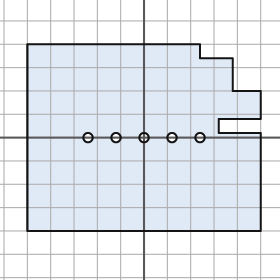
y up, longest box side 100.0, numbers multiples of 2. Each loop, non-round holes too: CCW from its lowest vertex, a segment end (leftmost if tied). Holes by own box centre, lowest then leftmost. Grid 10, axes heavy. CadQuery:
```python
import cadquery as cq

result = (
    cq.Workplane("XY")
    .moveTo(-50.0, -40.0)
    .lineTo(50.0, -40.0)
    .lineTo(50.0, 2.0)
    .lineTo(32.0, 2.0)
    .lineTo(32.0, 8.0)
    .lineTo(50.0, 8.0)
    .lineTo(50.0, 20.0)
    .lineTo(38.0, 20.0)
    .lineTo(38.0, 34.0)
    .lineTo(24.0, 34.0)
    .lineTo(24.0, 40.0)
    .lineTo(-50.0, 40.0)
    .close()
    .moveTo(-24.0, 0.0)
    .circle(2.0)
    .moveTo(-12.0, 0.0)
    .circle(2.0)
    .moveTo(0.0, 0.0)
    .circle(2.0)
    .moveTo(12.0, 0.0)
    .circle(2.0)
    .moveTo(24.0, 0.0)
    .circle(2.0)
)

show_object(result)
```